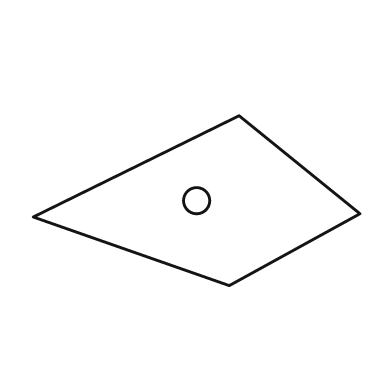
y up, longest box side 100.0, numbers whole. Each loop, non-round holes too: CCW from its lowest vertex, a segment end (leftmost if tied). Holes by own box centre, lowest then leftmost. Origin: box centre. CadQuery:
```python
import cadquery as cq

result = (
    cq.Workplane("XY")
    .moveTo(10.0, -26.0)
    .lineTo(50.0, -4.0)
    .lineTo(13.0, 26.0)
    .lineTo(-50.0, -5.0)
    .close()
    .moveTo(0.0, 0.0)
    .circle(4.0)
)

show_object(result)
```